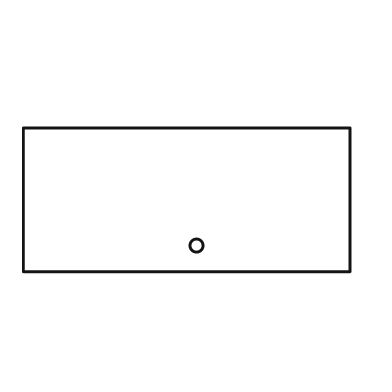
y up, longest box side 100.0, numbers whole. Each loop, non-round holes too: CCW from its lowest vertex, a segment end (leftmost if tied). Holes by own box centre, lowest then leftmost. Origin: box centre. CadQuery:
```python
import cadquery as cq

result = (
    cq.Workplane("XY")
    .moveTo(-50.0, -22.0)
    .lineTo(50.0, -22.0)
    .lineTo(50.0, 22.0)
    .lineTo(-50.0, 22.0)
    .close()
    .moveTo(3.0, -14.0)
    .circle(2.0)
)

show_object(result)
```